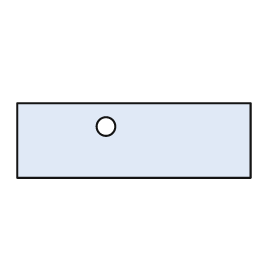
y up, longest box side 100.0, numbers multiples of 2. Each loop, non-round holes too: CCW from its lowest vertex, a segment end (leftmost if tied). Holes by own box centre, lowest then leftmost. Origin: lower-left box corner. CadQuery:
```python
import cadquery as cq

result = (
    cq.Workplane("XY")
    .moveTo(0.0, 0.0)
    .lineTo(100.0, 0.0)
    .lineTo(100.0, 32.0)
    .lineTo(0.0, 32.0)
    .close()
    .moveTo(38.0, 22.0)
    .circle(4.0)
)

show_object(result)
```